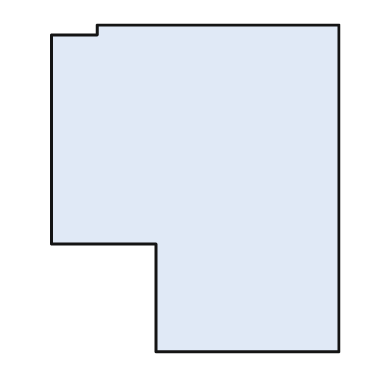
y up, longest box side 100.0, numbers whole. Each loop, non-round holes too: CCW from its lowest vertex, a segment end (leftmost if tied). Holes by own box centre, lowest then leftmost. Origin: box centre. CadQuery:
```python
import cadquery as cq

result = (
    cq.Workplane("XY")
    .moveTo(-12.0, -50.0)
    .lineTo(44.0, -50.0)
    .lineTo(44.0, 50.0)
    .lineTo(-30.0, 50.0)
    .lineTo(-30.0, 47.0)
    .lineTo(-44.0, 47.0)
    .lineTo(-44.0, -17.0)
    .lineTo(-12.0, -17.0)
    .close()
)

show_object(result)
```